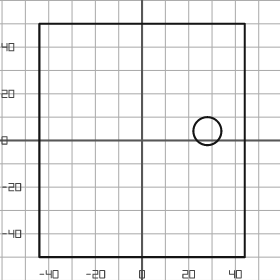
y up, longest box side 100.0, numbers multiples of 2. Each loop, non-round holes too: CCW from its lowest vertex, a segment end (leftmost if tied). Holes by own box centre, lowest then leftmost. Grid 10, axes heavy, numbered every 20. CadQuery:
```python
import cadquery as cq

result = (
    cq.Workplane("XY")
    .moveTo(-44.0, -50.0)
    .lineTo(44.0, -50.0)
    .lineTo(44.0, 50.0)
    .lineTo(-44.0, 50.0)
    .close()
    .moveTo(28.0, 4.0)
    .circle(6.0)
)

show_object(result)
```